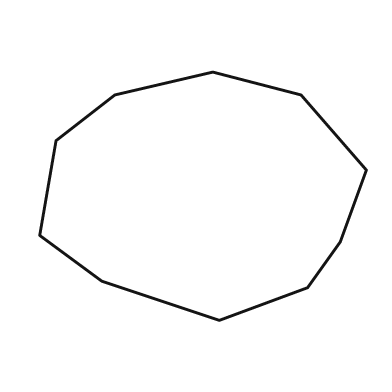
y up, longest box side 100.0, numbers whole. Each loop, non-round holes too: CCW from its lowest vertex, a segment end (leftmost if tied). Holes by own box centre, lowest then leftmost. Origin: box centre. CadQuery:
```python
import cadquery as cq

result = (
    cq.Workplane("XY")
    .moveTo(5.0, -38.0)
    .lineTo(32.0, -28.0)
    .lineTo(42.0, -14.0)
    .lineTo(50.0, 8.0)
    .lineTo(30.0, 31.0)
    .lineTo(3.0, 38.0)
    .lineTo(-27.0, 31.0)
    .lineTo(-45.0, 17.0)
    .lineTo(-50.0, -12.0)
    .lineTo(-31.0, -26.0)
    .close()
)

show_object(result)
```